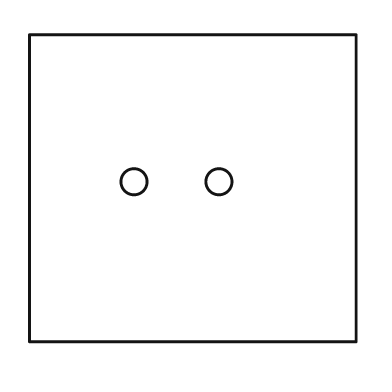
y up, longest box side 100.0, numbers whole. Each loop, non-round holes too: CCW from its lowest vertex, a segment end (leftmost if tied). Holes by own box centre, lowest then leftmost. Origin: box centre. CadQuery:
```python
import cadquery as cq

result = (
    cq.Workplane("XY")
    .moveTo(-50.0, -47.0)
    .lineTo(50.0, -47.0)
    .lineTo(50.0, 47.0)
    .lineTo(-50.0, 47.0)
    .close()
    .moveTo(-18.0, 2.0)
    .circle(4.0)
    .moveTo(8.0, 2.0)
    .circle(4.0)
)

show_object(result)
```